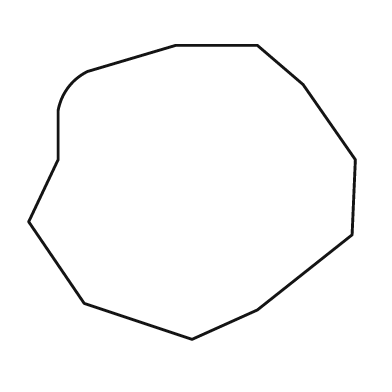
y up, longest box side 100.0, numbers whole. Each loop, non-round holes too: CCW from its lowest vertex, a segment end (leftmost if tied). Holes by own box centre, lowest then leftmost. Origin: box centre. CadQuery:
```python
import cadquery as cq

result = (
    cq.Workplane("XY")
    .moveTo(0.0, -45.0)
    .lineTo(20.0, -36.0)
    .lineTo(49.0, -13.0)
    .lineTo(50.0, 10.0)
    .lineTo(34.0, 33.0)
    .lineTo(20.0, 45.0)
    .lineTo(-5.0, 45.0)
    .lineTo(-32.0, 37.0)
    .threePointArc((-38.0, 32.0), (-41.0, 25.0))
    .lineTo(-41.0, 10.0)
    .lineTo(-50.0, -9.0)
    .lineTo(-33.0, -34.0)
    .close()
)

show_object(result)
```